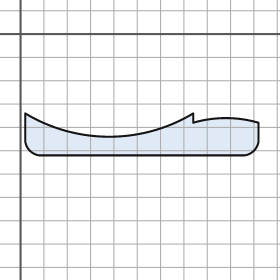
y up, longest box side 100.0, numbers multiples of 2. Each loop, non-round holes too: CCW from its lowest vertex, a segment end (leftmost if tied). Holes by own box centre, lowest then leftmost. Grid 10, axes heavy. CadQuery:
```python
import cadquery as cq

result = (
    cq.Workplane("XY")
    .moveTo(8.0, -52.0)
    .lineTo(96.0, -52.0)
    .threePointArc((100.0, -50.0), (102.0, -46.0))
    .lineTo(102.0, -38.0)
    .threePointArc((88.0, -36.0), (74.0, -38.0))
    .lineTo(74.0, -34.0)
    .threePointArc((38.0, -44.0), (2.0, -34.0))
    .lineTo(2.0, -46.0)
    .threePointArc((4.0, -50.0), (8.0, -52.0))
    .close()
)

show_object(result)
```